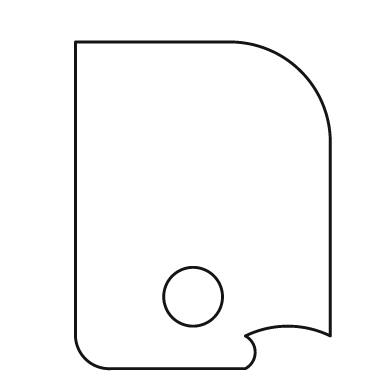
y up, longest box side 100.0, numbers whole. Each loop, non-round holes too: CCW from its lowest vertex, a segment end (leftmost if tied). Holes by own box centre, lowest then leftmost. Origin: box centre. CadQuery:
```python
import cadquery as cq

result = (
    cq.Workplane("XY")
    .moveTo(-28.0, -50.0)
    .lineTo(13.0, -50.0)
    .threePointArc((16.0, -45.0), (13.0, -40.0))
    .threePointArc((26.0, -37.0), (39.0, -40.0))
    .lineTo(39.0, 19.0)
    .threePointArc((30.0, 41.0), (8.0, 50.0))
    .lineTo(-39.0, 50.0)
    .lineTo(-39.0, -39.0)
    .threePointArc((-36.0, -47.0), (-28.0, -50.0))
    .close()
    .moveTo(-3.0, -28.0)
    .circle(9.0)
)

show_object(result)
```